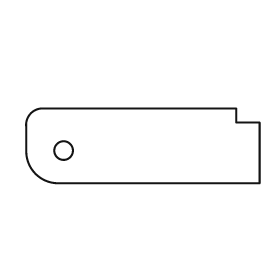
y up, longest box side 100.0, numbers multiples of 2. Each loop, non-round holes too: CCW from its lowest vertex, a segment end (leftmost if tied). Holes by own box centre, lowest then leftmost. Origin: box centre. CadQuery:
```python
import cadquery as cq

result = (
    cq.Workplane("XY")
    .moveTo(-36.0, -16.0)
    .lineTo(50.0, -16.0)
    .lineTo(50.0, 10.0)
    .lineTo(40.0, 10.0)
    .lineTo(40.0, 16.0)
    .lineTo(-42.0, 16.0)
    .threePointArc((-48.0, 14.0), (-50.0, 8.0))
    .lineTo(-50.0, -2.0)
    .threePointArc((-46.0, -12.0), (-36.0, -16.0))
    .close()
    .moveTo(-34.0, -2.0)
    .circle(4.0)
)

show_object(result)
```